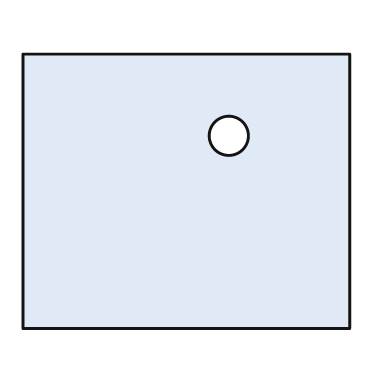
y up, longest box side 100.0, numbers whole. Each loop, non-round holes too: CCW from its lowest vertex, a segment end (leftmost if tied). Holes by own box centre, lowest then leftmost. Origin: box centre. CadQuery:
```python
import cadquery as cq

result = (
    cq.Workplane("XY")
    .moveTo(-50.0, -42.0)
    .lineTo(50.0, -42.0)
    .lineTo(50.0, 42.0)
    .lineTo(-50.0, 42.0)
    .close()
    .moveTo(13.0, 17.0)
    .circle(6.0)
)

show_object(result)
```